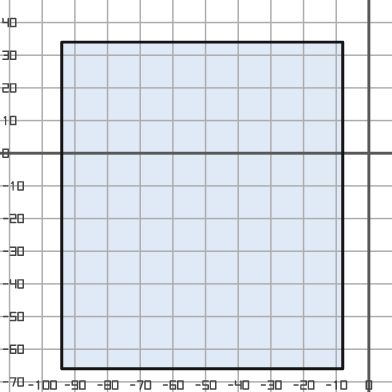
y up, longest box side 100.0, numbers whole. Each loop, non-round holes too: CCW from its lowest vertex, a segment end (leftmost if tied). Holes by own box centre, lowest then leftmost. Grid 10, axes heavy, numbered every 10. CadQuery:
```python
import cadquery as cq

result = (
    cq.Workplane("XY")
    .moveTo(-94.0, -66.0)
    .lineTo(-8.0, -66.0)
    .lineTo(-8.0, 34.0)
    .lineTo(-94.0, 34.0)
    .close()
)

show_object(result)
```